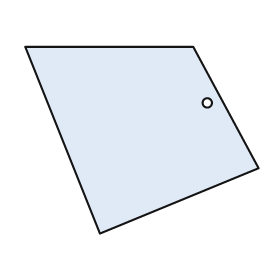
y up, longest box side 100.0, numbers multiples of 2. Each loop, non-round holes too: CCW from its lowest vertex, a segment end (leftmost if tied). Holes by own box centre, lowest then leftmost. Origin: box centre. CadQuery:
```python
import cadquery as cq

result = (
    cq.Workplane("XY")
    .moveTo(-18.0, -40.0)
    .lineTo(50.0, -12.0)
    .lineTo(22.0, 40.0)
    .lineTo(-50.0, 40.0)
    .close()
    .moveTo(28.0, 16.0)
    .circle(2.0)
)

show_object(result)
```